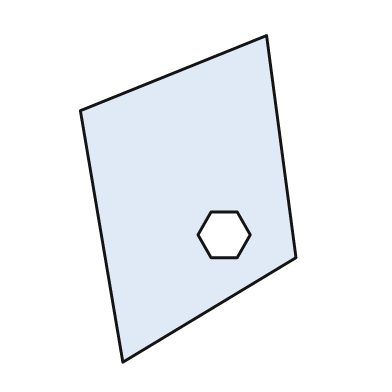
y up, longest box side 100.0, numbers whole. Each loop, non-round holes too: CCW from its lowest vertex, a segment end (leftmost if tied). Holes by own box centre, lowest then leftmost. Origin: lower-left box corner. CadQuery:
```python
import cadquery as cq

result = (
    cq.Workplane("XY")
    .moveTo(13.0, 0.0)
    .lineTo(66.0, 32.0)
    .lineTo(57.0, 100.0)
    .lineTo(0.0, 77.0)
    .close()
    .moveTo(40.0, 32.0)
    .lineTo(48.0, 32.0)
    .lineTo(52.0, 39.0)
    .lineTo(48.0, 46.0)
    .lineTo(40.0, 46.0)
    .lineTo(36.0, 39.0)
    .close()
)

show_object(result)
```